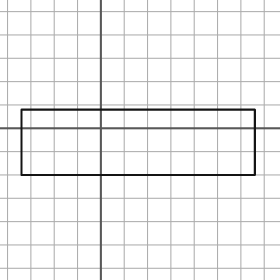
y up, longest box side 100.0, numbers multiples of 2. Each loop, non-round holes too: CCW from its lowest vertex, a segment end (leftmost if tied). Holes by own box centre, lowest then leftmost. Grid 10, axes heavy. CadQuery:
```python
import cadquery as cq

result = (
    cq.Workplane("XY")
    .moveTo(-34.0, -20.0)
    .lineTo(66.0, -20.0)
    .lineTo(66.0, 8.0)
    .lineTo(-34.0, 8.0)
    .close()
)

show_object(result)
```